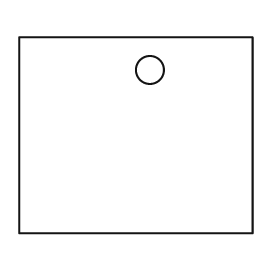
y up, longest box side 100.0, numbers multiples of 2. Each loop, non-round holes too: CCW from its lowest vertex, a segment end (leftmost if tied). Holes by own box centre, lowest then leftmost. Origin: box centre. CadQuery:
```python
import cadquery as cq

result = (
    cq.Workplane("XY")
    .moveTo(-50.0, -42.0)
    .lineTo(50.0, -42.0)
    .lineTo(50.0, 42.0)
    .lineTo(-50.0, 42.0)
    .close()
    .moveTo(6.0, 28.0)
    .circle(6.0)
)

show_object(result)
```